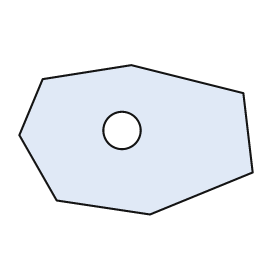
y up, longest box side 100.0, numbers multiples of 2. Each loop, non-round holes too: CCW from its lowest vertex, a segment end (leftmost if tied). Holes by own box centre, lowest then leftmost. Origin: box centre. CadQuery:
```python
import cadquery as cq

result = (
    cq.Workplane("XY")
    .moveTo(6.0, -32.0)
    .lineTo(50.0, -14.0)
    .lineTo(46.0, 20.0)
    .lineTo(-2.0, 32.0)
    .lineTo(-40.0, 26.0)
    .lineTo(-50.0, 2.0)
    .lineTo(-34.0, -26.0)
    .close()
    .moveTo(-6.0, 4.0)
    .circle(8.0)
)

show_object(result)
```